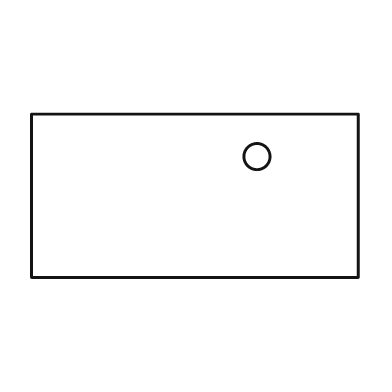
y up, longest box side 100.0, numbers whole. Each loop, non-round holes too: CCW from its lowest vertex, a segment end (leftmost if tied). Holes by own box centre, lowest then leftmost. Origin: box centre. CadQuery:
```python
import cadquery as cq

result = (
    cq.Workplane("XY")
    .moveTo(-50.0, -25.0)
    .lineTo(50.0, -25.0)
    .lineTo(50.0, 25.0)
    .lineTo(-50.0, 25.0)
    .close()
    .moveTo(19.0, 12.0)
    .circle(4.0)
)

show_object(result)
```